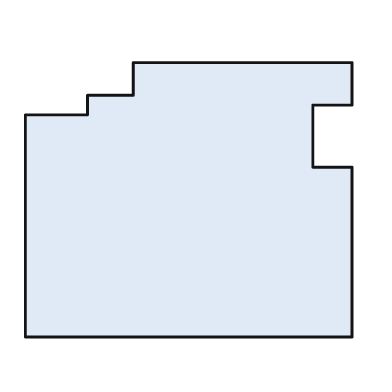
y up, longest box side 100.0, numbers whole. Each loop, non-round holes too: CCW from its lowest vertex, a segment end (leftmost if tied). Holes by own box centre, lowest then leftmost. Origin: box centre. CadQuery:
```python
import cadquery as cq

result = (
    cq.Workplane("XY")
    .moveTo(-50.0, -42.0)
    .lineTo(50.0, -42.0)
    .lineTo(50.0, 10.0)
    .lineTo(38.0, 10.0)
    .lineTo(38.0, 29.0)
    .lineTo(50.0, 29.0)
    .lineTo(50.0, 42.0)
    .lineTo(-17.0, 42.0)
    .lineTo(-17.0, 32.0)
    .lineTo(-31.0, 32.0)
    .lineTo(-31.0, 26.0)
    .lineTo(-50.0, 26.0)
    .close()
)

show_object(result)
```